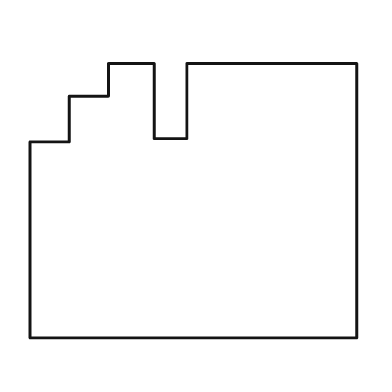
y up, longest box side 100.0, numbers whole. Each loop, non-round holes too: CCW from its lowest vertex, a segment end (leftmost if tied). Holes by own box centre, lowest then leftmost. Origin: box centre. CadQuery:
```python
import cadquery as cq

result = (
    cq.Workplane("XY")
    .moveTo(-50.0, -42.0)
    .lineTo(50.0, -42.0)
    .lineTo(50.0, 42.0)
    .lineTo(-2.0, 42.0)
    .lineTo(-2.0, 19.0)
    .lineTo(-12.0, 19.0)
    .lineTo(-12.0, 42.0)
    .lineTo(-26.0, 42.0)
    .lineTo(-26.0, 32.0)
    .lineTo(-38.0, 32.0)
    .lineTo(-38.0, 18.0)
    .lineTo(-50.0, 18.0)
    .close()
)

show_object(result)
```